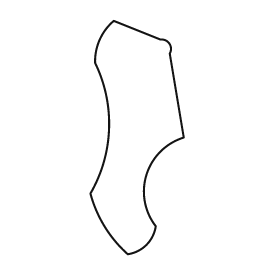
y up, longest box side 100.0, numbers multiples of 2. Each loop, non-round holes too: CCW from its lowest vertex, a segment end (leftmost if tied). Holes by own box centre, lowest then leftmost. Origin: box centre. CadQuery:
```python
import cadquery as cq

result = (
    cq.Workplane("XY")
    .moveTo(-4.0, -50.0)
    .threePointArc((4.0, -46.0), (8.0, -38.0))
    .threePointArc((4.0, -16.0), (20.0, 0.0))
    .lineTo(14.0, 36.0)
    .threePointArc((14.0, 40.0), (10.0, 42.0))
    .lineTo(-10.0, 50.0)
    .threePointArc((-16.0, 42.0), (-18.0, 32.0))
    .threePointArc((-12.0, 4.0), (-20.0, -24.0))
    .threePointArc((-14.0, -38.0), (-4.0, -50.0))
    .close()
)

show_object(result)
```